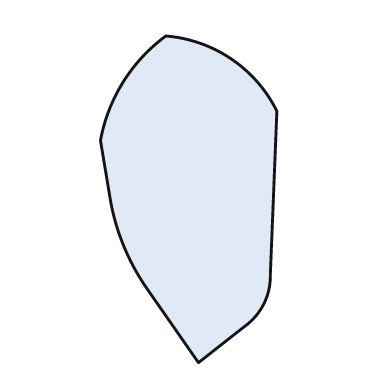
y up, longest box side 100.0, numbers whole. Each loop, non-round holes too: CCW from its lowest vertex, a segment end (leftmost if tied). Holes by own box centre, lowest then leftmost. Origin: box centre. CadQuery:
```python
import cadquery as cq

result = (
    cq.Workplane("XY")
    .moveTo(3.0, -50.0)
    .lineTo(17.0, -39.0)
    .threePointArc((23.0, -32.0), (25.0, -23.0))
    .lineTo(27.0, 27.0)
    .threePointArc((13.0, 43.0), (-7.0, 50.0))
    .threePointArc((-20.0, 36.0), (-27.0, 18.0))
    .lineTo(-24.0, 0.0)
    .threePointArc((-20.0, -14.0), (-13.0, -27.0))
    .close()
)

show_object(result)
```